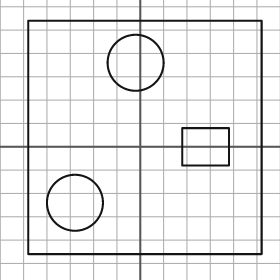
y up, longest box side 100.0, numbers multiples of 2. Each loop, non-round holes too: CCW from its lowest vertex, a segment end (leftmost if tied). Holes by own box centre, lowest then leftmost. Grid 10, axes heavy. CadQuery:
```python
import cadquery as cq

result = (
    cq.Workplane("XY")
    .moveTo(-48.0, -46.0)
    .lineTo(52.0, -46.0)
    .lineTo(52.0, 54.0)
    .lineTo(-48.0, 54.0)
    .close()
    .moveTo(-28.0, -24.0)
    .circle(12.0)
    .moveTo(18.0, -8.0)
    .lineTo(38.0, -8.0)
    .lineTo(38.0, 8.0)
    .lineTo(18.0, 8.0)
    .close()
    .moveTo(-2.0, 36.0)
    .circle(12.0)
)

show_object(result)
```